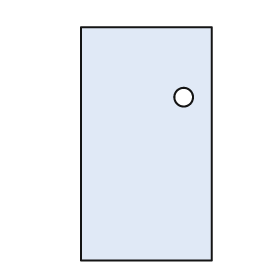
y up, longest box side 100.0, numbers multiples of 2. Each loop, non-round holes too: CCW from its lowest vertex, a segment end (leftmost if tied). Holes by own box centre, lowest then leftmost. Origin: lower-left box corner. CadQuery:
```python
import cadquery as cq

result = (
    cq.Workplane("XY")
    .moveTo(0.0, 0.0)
    .lineTo(56.0, 0.0)
    .lineTo(56.0, 100.0)
    .lineTo(0.0, 100.0)
    .close()
    .moveTo(44.0, 70.0)
    .circle(4.0)
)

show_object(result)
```